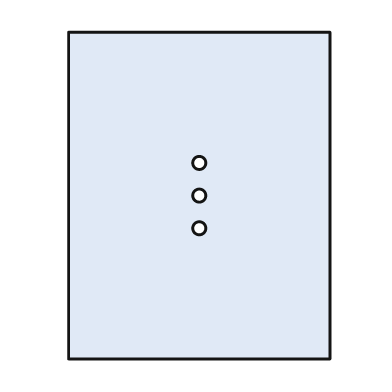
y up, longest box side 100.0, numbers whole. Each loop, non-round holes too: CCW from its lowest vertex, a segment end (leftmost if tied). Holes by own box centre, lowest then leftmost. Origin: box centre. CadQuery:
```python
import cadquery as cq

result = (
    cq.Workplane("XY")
    .moveTo(-40.0, -50.0)
    .lineTo(40.0, -50.0)
    .lineTo(40.0, 50.0)
    .lineTo(-40.0, 50.0)
    .close()
    .moveTo(0.0, -10.0)
    .circle(2.0)
    .moveTo(0.0, 0.0)
    .circle(2.0)
    .moveTo(0.0, 10.0)
    .circle(2.0)
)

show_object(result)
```